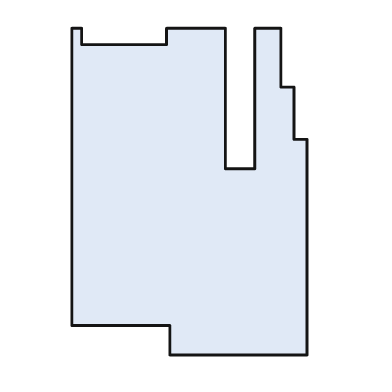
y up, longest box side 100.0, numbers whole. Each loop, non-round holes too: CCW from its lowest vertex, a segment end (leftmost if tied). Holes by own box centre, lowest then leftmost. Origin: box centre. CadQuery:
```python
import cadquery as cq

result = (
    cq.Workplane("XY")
    .moveTo(-6.0, -50.0)
    .lineTo(36.0, -50.0)
    .lineTo(36.0, 16.0)
    .lineTo(32.0, 16.0)
    .lineTo(32.0, 32.0)
    .lineTo(28.0, 32.0)
    .lineTo(28.0, 50.0)
    .lineTo(20.0, 50.0)
    .lineTo(20.0, 7.0)
    .lineTo(11.0, 7.0)
    .lineTo(11.0, 50.0)
    .lineTo(-7.0, 50.0)
    .lineTo(-7.0, 45.0)
    .lineTo(-33.0, 45.0)
    .lineTo(-33.0, 50.0)
    .lineTo(-36.0, 50.0)
    .lineTo(-36.0, -41.0)
    .lineTo(-6.0, -41.0)
    .close()
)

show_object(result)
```